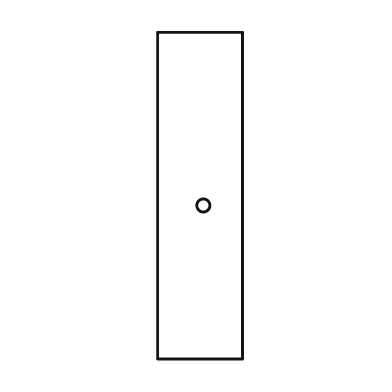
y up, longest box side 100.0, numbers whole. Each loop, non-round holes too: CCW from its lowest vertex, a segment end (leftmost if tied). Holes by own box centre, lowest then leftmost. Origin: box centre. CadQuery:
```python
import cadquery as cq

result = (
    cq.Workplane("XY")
    .moveTo(-13.0, -50.0)
    .lineTo(13.0, -50.0)
    .lineTo(13.0, 50.0)
    .lineTo(-13.0, 50.0)
    .close()
    .moveTo(1.0, -3.0)
    .circle(2.0)
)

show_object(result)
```